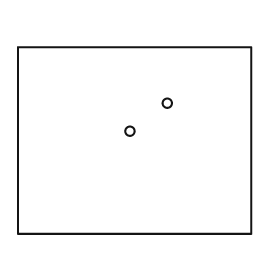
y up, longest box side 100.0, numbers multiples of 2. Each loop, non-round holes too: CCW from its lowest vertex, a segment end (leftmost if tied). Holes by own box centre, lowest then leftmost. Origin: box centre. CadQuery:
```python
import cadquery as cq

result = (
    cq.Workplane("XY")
    .moveTo(-50.0, -40.0)
    .lineTo(50.0, -40.0)
    .lineTo(50.0, 40.0)
    .lineTo(-50.0, 40.0)
    .close()
    .moveTo(-2.0, 4.0)
    .circle(2.0)
    .moveTo(14.0, 16.0)
    .circle(2.0)
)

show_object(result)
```